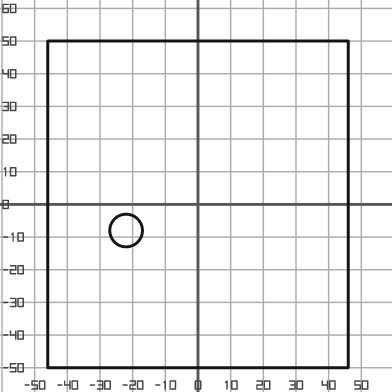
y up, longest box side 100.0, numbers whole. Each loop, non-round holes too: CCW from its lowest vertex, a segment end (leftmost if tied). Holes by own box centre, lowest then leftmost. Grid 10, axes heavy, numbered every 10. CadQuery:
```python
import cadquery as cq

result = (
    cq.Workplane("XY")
    .moveTo(-46.0, -50.0)
    .lineTo(46.0, -50.0)
    .lineTo(46.0, 50.0)
    .lineTo(-46.0, 50.0)
    .close()
    .moveTo(-22.0, -8.0)
    .circle(5.0)
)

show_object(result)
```